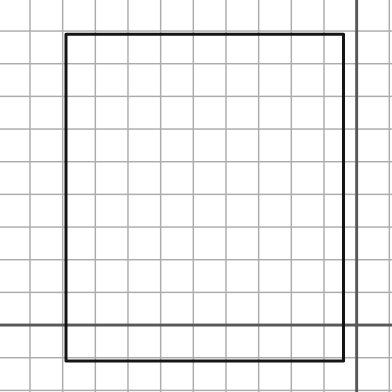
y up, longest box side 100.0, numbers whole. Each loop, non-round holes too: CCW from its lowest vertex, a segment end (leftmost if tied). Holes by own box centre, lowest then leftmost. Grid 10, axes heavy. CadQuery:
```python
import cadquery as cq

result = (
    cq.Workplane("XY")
    .moveTo(-89.0, -11.0)
    .lineTo(-4.0, -11.0)
    .lineTo(-4.0, 89.0)
    .lineTo(-89.0, 89.0)
    .close()
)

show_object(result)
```